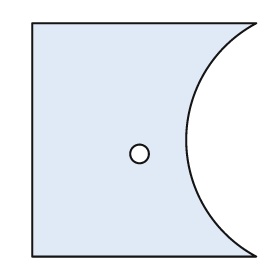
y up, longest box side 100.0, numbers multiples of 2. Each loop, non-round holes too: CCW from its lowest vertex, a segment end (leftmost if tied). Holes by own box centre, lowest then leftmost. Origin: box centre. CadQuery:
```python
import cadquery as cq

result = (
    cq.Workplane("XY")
    .moveTo(-48.0, -50.0)
    .lineTo(48.0, -50.0)
    .threePointArc((18.0, 0.0), (48.0, 50.0))
    .lineTo(-48.0, 50.0)
    .close()
    .moveTo(-2.0, -6.0)
    .circle(4.0)
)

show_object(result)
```